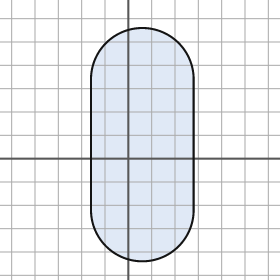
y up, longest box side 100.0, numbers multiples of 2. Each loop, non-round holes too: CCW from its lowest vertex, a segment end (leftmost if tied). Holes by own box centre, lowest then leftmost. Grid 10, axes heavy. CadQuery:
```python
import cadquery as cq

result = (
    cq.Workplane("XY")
    .moveTo(-16.0, -22.0)
    .threePointArc((6.0, -44.0), (28.0, -22.0))
    .lineTo(28.0, 34.0)
    .threePointArc((6.0, 56.0), (-16.0, 34.0))
    .close()
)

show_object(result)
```